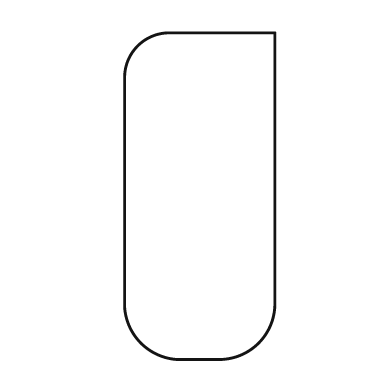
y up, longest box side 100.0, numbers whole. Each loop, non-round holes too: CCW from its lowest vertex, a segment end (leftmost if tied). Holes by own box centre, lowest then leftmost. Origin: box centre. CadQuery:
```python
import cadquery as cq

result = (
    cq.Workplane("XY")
    .moveTo(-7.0, -50.0)
    .lineTo(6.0, -50.0)
    .threePointArc((18.0, -45.0), (23.0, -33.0))
    .lineTo(23.0, 50.0)
    .lineTo(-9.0, 50.0)
    .threePointArc((-19.0, 46.0), (-23.0, 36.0))
    .lineTo(-23.0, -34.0)
    .threePointArc((-18.0, -45.0), (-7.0, -50.0))
    .close()
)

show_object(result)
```